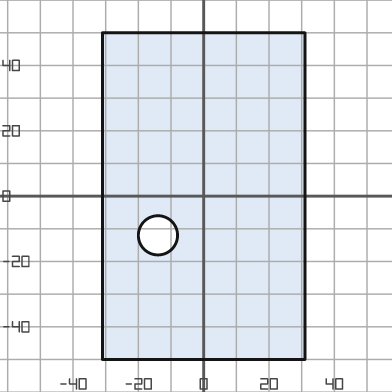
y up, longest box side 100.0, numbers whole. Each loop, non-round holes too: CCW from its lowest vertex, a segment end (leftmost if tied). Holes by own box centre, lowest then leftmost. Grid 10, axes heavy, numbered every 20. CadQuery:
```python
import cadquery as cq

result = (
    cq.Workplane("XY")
    .moveTo(-31.0, -50.0)
    .lineTo(31.0, -50.0)
    .lineTo(31.0, 50.0)
    .lineTo(-31.0, 50.0)
    .close()
    .moveTo(-14.0, -12.0)
    .circle(6.0)
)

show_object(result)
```